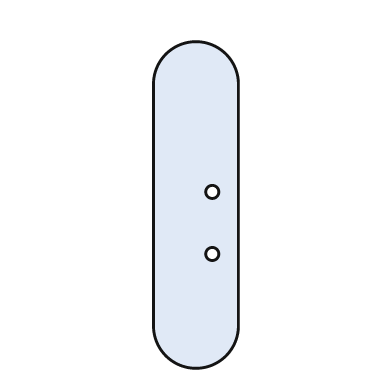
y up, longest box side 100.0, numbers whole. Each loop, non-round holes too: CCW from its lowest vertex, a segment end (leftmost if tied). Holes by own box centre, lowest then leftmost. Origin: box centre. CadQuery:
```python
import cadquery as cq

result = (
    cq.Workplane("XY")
    .moveTo(-13.0, -37.0)
    .threePointArc((0.0, -50.0), (13.0, -37.0))
    .lineTo(13.0, 37.0)
    .threePointArc((0.0, 50.0), (-13.0, 37.0))
    .close()
    .moveTo(5.0, -15.0)
    .circle(2.0)
    .moveTo(5.0, 4.0)
    .circle(2.0)
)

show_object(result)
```